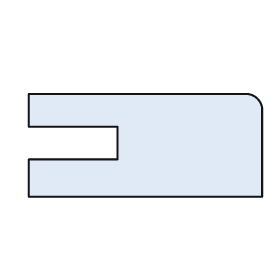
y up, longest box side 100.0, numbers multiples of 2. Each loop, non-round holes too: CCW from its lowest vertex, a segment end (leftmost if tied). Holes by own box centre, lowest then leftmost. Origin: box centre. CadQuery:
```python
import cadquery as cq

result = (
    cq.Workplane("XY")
    .moveTo(-50.0, -22.0)
    .lineTo(50.0, -22.0)
    .lineTo(50.0, 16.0)
    .threePointArc((48.0, 20.0), (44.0, 22.0))
    .lineTo(-50.0, 22.0)
    .lineTo(-50.0, 8.0)
    .lineTo(-12.0, 8.0)
    .lineTo(-12.0, -6.0)
    .lineTo(-50.0, -6.0)
    .close()
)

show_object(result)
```